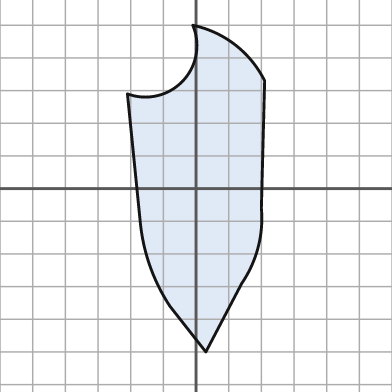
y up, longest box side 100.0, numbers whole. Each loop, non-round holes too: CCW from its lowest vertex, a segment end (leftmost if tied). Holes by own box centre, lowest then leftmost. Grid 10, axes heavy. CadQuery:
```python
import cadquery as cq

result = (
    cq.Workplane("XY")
    .moveTo(3.0, -50.0)
    .lineTo(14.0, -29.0)
    .threePointArc((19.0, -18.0), (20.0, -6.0))
    .lineTo(21.0, 33.0)
    .threePointArc((12.0, 44.0), (-1.0, 50.0))
    .threePointArc((-4.0, 33.0), (-21.0, 29.0))
    .lineTo(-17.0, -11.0)
    .threePointArc((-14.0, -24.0), (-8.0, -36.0))
    .close()
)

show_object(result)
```